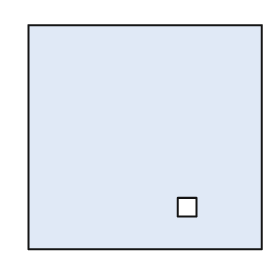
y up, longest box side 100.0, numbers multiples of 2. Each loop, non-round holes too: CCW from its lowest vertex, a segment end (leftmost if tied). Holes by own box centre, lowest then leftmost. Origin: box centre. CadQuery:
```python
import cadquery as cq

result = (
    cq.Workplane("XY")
    .moveTo(-50.0, -48.0)
    .lineTo(50.0, -48.0)
    .lineTo(50.0, 48.0)
    .lineTo(-50.0, 48.0)
    .close()
    .moveTo(14.0, -34.0)
    .lineTo(22.0, -34.0)
    .lineTo(22.0, -26.0)
    .lineTo(14.0, -26.0)
    .close()
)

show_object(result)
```